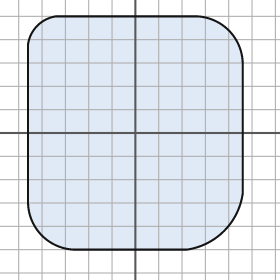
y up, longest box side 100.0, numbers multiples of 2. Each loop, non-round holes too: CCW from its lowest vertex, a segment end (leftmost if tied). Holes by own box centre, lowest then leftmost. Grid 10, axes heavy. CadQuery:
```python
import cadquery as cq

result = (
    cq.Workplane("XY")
    .moveTo(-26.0, -50.0)
    .lineTo(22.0, -50.0)
    .threePointArc((38.0, -42.0), (46.0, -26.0))
    .lineTo(46.0, 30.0)
    .threePointArc((40.0, 44.0), (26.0, 50.0))
    .lineTo(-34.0, 50.0)
    .threePointArc((-42.0, 46.0), (-46.0, 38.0))
    .lineTo(-46.0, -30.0)
    .threePointArc((-40.0, -44.0), (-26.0, -50.0))
    .close()
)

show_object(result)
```